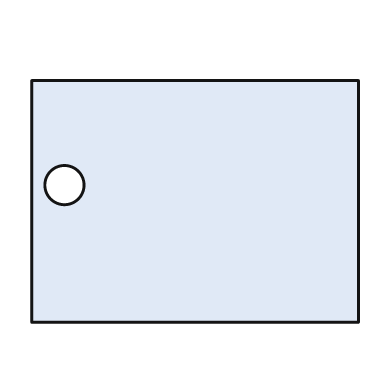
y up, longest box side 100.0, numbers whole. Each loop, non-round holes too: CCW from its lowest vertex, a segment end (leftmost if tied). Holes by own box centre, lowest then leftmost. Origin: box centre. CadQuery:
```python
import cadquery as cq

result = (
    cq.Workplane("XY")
    .moveTo(-50.0, -37.0)
    .lineTo(50.0, -37.0)
    .lineTo(50.0, 37.0)
    .lineTo(-50.0, 37.0)
    .close()
    .moveTo(-40.0, 5.0)
    .circle(6.0)
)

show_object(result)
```